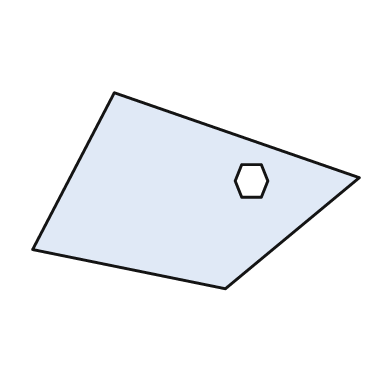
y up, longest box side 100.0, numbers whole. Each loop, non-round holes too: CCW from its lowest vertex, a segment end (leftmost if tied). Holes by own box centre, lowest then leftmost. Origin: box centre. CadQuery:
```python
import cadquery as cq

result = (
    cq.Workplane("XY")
    .moveTo(9.0, -30.0)
    .lineTo(50.0, 4.0)
    .lineTo(-25.0, 30.0)
    .lineTo(-50.0, -18.0)
    .close()
    .moveTo(14.0, -2.0)
    .lineTo(20.0, -2.0)
    .lineTo(22.0, 3.0)
    .lineTo(20.0, 8.0)
    .lineTo(14.0, 8.0)
    .lineTo(12.0, 3.0)
    .close()
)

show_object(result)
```